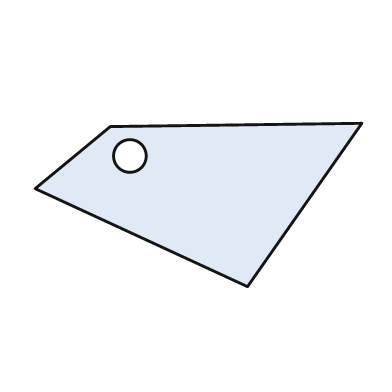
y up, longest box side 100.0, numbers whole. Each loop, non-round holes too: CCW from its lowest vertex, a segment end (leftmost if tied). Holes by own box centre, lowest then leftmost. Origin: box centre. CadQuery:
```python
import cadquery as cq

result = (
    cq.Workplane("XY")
    .moveTo(15.0, -25.0)
    .lineTo(50.0, 25.0)
    .lineTo(-27.0, 24.0)
    .lineTo(-50.0, 5.0)
    .close()
    .moveTo(-21.0, 15.0)
    .circle(5.0)
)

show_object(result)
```